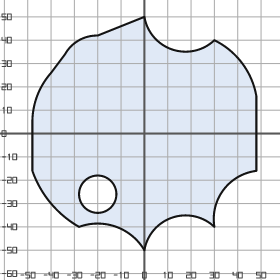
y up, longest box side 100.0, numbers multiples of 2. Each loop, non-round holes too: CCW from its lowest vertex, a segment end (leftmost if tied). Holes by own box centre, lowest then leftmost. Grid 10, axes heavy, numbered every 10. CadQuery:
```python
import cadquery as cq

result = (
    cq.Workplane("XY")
    .moveTo(0.0, -50.0)
    .threePointArc((12.0, -36.0), (30.0, -40.0))
    .threePointArc((34.0, -24.0), (48.0, -16.0))
    .lineTo(48.0, 16.0)
    .threePointArc((42.0, 30.0), (30.0, 40.0))
    .threePointArc((12.0, 36.0), (0.0, 50.0))
    .lineTo(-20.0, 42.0)
    .threePointArc((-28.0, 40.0), (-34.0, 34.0))
    .lineTo(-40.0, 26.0)
    .threePointArc((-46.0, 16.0), (-48.0, 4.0))
    .lineTo(-48.0, -16.0)
    .threePointArc((-40.0, -30.0), (-28.0, -40.0))
    .threePointArc((-12.0, -40.0), (0.0, -50.0))
    .close()
    .moveTo(-20.0, -26.0)
    .circle(8.0)
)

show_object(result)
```